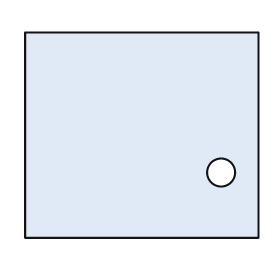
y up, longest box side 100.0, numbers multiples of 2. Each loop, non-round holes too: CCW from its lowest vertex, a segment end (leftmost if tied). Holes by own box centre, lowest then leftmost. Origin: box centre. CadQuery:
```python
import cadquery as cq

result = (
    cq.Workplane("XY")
    .moveTo(-50.0, -44.0)
    .lineTo(50.0, -44.0)
    .lineTo(50.0, 44.0)
    .lineTo(-50.0, 44.0)
    .close()
    .moveTo(34.0, -16.0)
    .circle(6.0)
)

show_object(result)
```